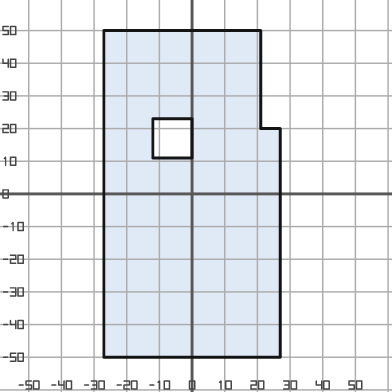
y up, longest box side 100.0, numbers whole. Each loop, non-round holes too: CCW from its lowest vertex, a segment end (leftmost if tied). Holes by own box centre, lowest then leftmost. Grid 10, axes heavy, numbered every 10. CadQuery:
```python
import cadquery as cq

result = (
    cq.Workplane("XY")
    .moveTo(-27.0, -50.0)
    .lineTo(27.0, -50.0)
    .lineTo(27.0, 20.0)
    .lineTo(21.0, 20.0)
    .lineTo(21.0, 50.0)
    .lineTo(-27.0, 50.0)
    .close()
    .moveTo(-12.0, 11.0)
    .lineTo(0.0, 11.0)
    .lineTo(0.0, 23.0)
    .lineTo(-12.0, 23.0)
    .close()
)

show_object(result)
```